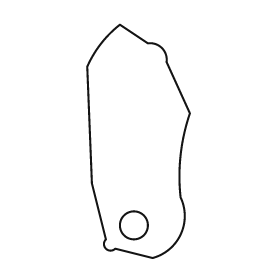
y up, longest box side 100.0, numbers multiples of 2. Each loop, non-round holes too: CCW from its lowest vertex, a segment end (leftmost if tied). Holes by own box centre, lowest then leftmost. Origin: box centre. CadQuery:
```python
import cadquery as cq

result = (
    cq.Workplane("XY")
    .moveTo(6.0, -50.0)
    .threePointArc((18.0, -40.0), (18.0, -24.0))
    .threePointArc((18.0, -6.0), (22.0, 12.0))
    .lineTo(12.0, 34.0)
    .threePointArc((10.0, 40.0), (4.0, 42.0))
    .lineTo(-8.0, 50.0)
    .threePointArc((-16.0, 42.0), (-22.0, 32.0))
    .lineTo(-20.0, -18.0)
    .lineTo(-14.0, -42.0)
    .threePointArc((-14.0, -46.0), (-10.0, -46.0))
    .close()
    .moveTo(-2.0, -36.0)
    .circle(6.0)
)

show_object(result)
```